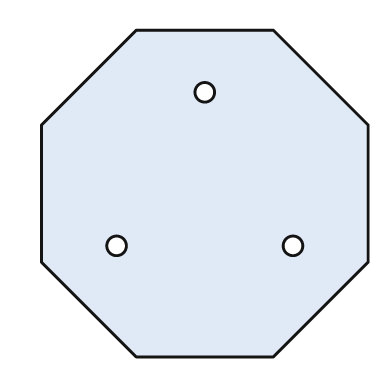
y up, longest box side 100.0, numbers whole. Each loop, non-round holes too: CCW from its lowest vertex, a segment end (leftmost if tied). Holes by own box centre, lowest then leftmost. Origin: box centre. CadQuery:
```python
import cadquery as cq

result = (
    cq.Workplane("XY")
    .moveTo(-21.0, -50.0)
    .lineTo(21.0, -50.0)
    .lineTo(50.0, -21.0)
    .lineTo(50.0, 21.0)
    .lineTo(21.0, 50.0)
    .lineTo(-21.0, 50.0)
    .lineTo(-50.0, 21.0)
    .lineTo(-50.0, -21.0)
    .close()
    .moveTo(-27.0, -16.0)
    .circle(3.0)
    .moveTo(27.0, -16.0)
    .circle(3.0)
    .moveTo(0.0, 31.0)
    .circle(3.0)
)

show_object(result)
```